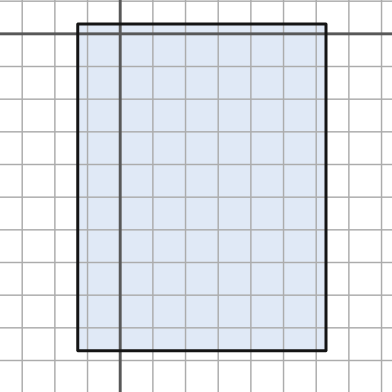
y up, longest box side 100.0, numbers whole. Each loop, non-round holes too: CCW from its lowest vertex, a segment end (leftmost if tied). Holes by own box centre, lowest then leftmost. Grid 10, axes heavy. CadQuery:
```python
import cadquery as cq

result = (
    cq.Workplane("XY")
    .moveTo(-13.0, -97.0)
    .lineTo(63.0, -97.0)
    .lineTo(63.0, 3.0)
    .lineTo(-13.0, 3.0)
    .close()
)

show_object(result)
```